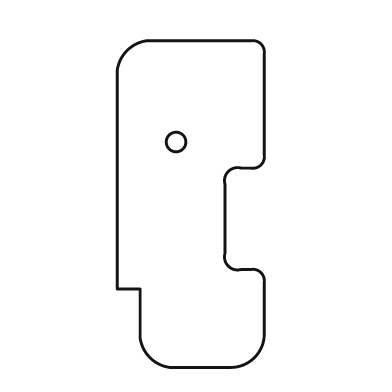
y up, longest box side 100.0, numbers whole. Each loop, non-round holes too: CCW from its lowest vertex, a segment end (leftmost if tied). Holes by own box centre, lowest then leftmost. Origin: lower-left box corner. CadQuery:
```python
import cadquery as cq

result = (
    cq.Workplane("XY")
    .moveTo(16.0, 0.0)
    .lineTo(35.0, 0.0)
    .threePointArc((42.0, 3.0), (45.0, 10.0))
    .lineTo(45.0, 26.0)
    .threePointArc((44.0, 29.0), (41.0, 30.0))
    .lineTo(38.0, 30.0)
    .threePointArc((34.0, 31.0), (33.0, 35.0))
    .lineTo(33.0, 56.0)
    .threePointArc((34.0, 60.0), (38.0, 61.0))
    .lineTo(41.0, 61.0)
    .threePointArc((44.0, 62.0), (45.0, 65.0))
    .lineTo(45.0, 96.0)
    .threePointArc((44.0, 99.0), (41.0, 100.0))
    .lineTo(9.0, 100.0)
    .threePointArc((3.0, 97.0), (0.0, 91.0))
    .lineTo(0.0, 24.0)
    .lineTo(7.0, 24.0)
    .lineTo(7.0, 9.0)
    .threePointArc((10.0, 3.0), (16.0, 0.0))
    .close()
    .moveTo(18.0, 69.0)
    .circle(3.0)
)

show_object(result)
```